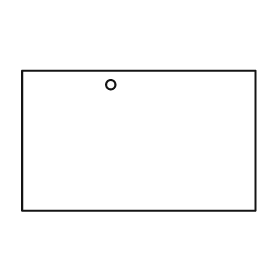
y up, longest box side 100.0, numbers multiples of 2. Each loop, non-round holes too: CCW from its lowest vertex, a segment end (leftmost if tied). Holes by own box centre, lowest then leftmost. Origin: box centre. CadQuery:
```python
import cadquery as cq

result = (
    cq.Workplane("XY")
    .moveTo(-50.0, -30.0)
    .lineTo(50.0, -30.0)
    .lineTo(50.0, 30.0)
    .lineTo(-50.0, 30.0)
    .close()
    .moveTo(-12.0, 24.0)
    .circle(2.0)
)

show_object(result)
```